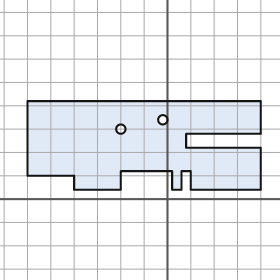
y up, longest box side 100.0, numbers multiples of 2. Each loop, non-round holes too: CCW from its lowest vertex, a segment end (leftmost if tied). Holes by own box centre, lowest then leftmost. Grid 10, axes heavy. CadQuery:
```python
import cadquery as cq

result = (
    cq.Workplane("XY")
    .moveTo(-40.0, 4.0)
    .lineTo(-20.0, 4.0)
    .lineTo(-20.0, 12.0)
    .lineTo(2.0, 12.0)
    .lineTo(2.0, 4.0)
    .lineTo(6.0, 4.0)
    .lineTo(6.0, 12.0)
    .lineTo(10.0, 12.0)
    .lineTo(10.0, 4.0)
    .lineTo(40.0, 4.0)
    .lineTo(40.0, 22.0)
    .lineTo(8.0, 22.0)
    .lineTo(8.0, 28.0)
    .lineTo(40.0, 28.0)
    .lineTo(40.0, 42.0)
    .lineTo(-60.0, 42.0)
    .lineTo(-60.0, 10.0)
    .lineTo(-40.0, 10.0)
    .close()
    .moveTo(-20.0, 30.0)
    .circle(2.0)
    .moveTo(-2.0, 34.0)
    .circle(2.0)
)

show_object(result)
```